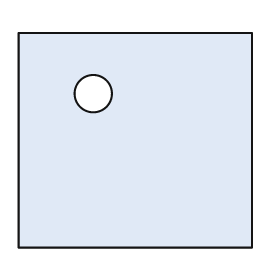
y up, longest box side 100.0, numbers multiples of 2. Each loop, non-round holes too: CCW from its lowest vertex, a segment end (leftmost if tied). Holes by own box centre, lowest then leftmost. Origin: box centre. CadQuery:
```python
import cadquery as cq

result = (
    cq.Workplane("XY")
    .moveTo(-50.0, -46.0)
    .lineTo(50.0, -46.0)
    .lineTo(50.0, 46.0)
    .lineTo(-50.0, 46.0)
    .close()
    .moveTo(-18.0, 20.0)
    .circle(8.0)
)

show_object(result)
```